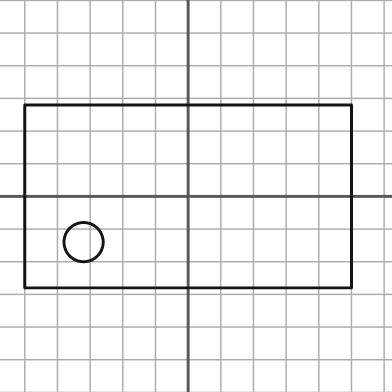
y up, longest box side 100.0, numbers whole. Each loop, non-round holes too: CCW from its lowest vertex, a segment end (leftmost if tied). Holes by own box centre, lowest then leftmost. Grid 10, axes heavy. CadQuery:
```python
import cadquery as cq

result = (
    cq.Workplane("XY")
    .moveTo(-50.0, -28.0)
    .lineTo(50.0, -28.0)
    .lineTo(50.0, 28.0)
    .lineTo(-50.0, 28.0)
    .close()
    .moveTo(-32.0, -14.0)
    .circle(6.0)
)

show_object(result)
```